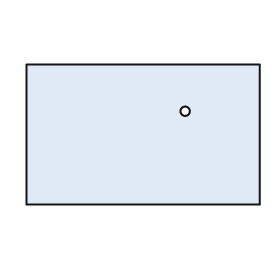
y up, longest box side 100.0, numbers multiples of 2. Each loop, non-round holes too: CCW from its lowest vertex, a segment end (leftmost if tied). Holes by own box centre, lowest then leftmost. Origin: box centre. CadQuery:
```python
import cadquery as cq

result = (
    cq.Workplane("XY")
    .moveTo(-50.0, -30.0)
    .lineTo(50.0, -30.0)
    .lineTo(50.0, 30.0)
    .lineTo(-50.0, 30.0)
    .close()
    .moveTo(18.0, 10.0)
    .circle(2.0)
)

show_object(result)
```